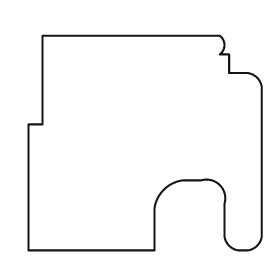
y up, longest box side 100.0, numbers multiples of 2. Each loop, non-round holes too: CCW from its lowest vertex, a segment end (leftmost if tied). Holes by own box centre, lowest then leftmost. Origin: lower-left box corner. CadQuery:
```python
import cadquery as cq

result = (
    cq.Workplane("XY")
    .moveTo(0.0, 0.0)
    .lineTo(54.0, 0.0)
    .lineTo(54.0, 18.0)
    .threePointArc((58.0, 26.0), (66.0, 30.0))
    .lineTo(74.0, 30.0)
    .threePointArc((82.0, 28.0), (84.0, 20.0))
    .lineTo(84.0, 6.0)
    .threePointArc((86.0, 2.0), (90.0, 0.0))
    .lineTo(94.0, 0.0)
    .threePointArc((98.0, 2.0), (100.0, 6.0))
    .lineTo(100.0, 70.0)
    .threePointArc((98.0, 74.0), (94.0, 76.0))
    .lineTo(86.0, 76.0)
    .lineTo(86.0, 84.0)
    .lineTo(82.0, 84.0)
    .threePointArc((84.0, 88.0), (82.0, 92.0))
    .lineTo(6.0, 92.0)
    .lineTo(6.0, 54.0)
    .lineTo(0.0, 54.0)
    .close()
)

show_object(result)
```